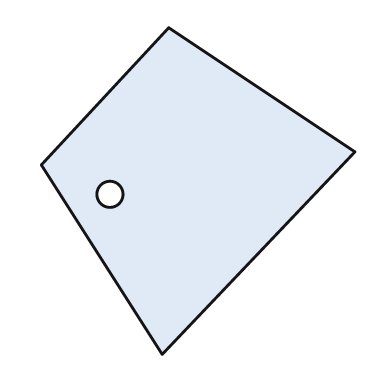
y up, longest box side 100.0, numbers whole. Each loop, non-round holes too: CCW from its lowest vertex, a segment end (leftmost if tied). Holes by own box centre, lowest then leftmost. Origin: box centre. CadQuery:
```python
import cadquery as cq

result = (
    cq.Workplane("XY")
    .moveTo(-11.0, -50.0)
    .lineTo(48.0, 12.0)
    .lineTo(-9.0, 50.0)
    .lineTo(-48.0, 8.0)
    .close()
    .moveTo(-27.0, -1.0)
    .circle(4.0)
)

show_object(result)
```